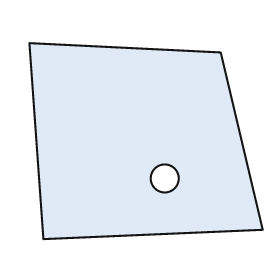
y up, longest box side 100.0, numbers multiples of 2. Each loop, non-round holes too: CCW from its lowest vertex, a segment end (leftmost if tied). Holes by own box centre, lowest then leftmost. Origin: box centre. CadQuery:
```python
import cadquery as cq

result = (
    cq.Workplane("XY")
    .moveTo(-44.0, -42.0)
    .lineTo(50.0, -38.0)
    .lineTo(32.0, 38.0)
    .lineTo(-50.0, 42.0)
    .close()
    .moveTo(8.0, -16.0)
    .circle(6.0)
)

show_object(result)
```